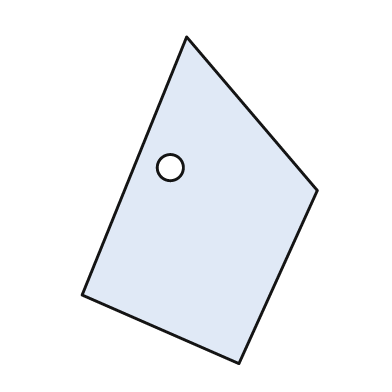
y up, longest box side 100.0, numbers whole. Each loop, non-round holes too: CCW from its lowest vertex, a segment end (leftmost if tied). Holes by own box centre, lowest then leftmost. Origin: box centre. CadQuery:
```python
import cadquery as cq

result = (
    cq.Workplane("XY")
    .moveTo(12.0, -50.0)
    .lineTo(36.0, 3.0)
    .lineTo(-4.0, 50.0)
    .lineTo(-36.0, -29.0)
    .close()
    .moveTo(-9.0, 10.0)
    .circle(4.0)
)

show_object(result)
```